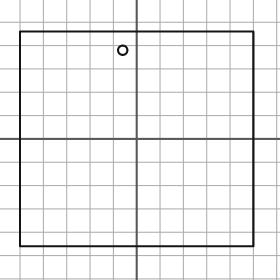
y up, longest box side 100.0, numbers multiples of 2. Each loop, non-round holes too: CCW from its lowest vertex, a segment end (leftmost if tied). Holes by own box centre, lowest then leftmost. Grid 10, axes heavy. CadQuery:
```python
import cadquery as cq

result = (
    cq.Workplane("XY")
    .moveTo(-50.0, -46.0)
    .lineTo(50.0, -46.0)
    .lineTo(50.0, 46.0)
    .lineTo(-50.0, 46.0)
    .close()
    .moveTo(-6.0, 38.0)
    .circle(2.0)
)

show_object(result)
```